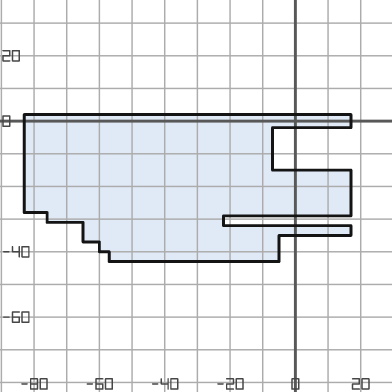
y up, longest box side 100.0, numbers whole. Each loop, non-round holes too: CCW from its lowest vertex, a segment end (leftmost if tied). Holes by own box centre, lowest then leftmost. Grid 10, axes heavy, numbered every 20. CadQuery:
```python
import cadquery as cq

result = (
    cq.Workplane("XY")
    .moveTo(-57.0, -43.0)
    .lineTo(-5.0, -43.0)
    .lineTo(-5.0, -35.0)
    .lineTo(17.0, -35.0)
    .lineTo(17.0, -32.0)
    .lineTo(-22.0, -32.0)
    .lineTo(-22.0, -29.0)
    .lineTo(17.0, -29.0)
    .lineTo(17.0, -15.0)
    .lineTo(-7.0, -15.0)
    .lineTo(-7.0, -2.0)
    .lineTo(17.0, -2.0)
    .lineTo(17.0, 2.0)
    .lineTo(-83.0, 2.0)
    .lineTo(-83.0, -28.0)
    .lineTo(-76.0, -28.0)
    .lineTo(-76.0, -31.0)
    .lineTo(-65.0, -31.0)
    .lineTo(-65.0, -37.0)
    .lineTo(-60.0, -37.0)
    .lineTo(-60.0, -40.0)
    .lineTo(-57.0, -40.0)
    .close()
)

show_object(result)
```